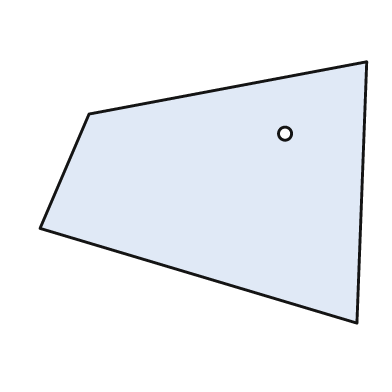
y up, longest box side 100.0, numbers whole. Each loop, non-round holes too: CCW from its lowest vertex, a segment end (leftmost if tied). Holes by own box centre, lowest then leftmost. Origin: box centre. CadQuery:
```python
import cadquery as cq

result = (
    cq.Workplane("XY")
    .moveTo(47.0, -40.0)
    .lineTo(50.0, 40.0)
    .lineTo(-35.0, 24.0)
    .lineTo(-50.0, -11.0)
    .close()
    .moveTo(25.0, 18.0)
    .circle(2.0)
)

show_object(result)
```